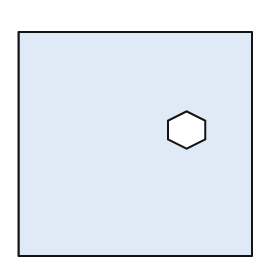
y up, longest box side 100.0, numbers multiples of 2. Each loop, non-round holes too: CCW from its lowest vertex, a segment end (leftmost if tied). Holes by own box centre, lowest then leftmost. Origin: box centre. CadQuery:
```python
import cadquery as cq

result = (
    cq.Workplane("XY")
    .moveTo(-50.0, -48.0)
    .lineTo(50.0, -48.0)
    .lineTo(50.0, 48.0)
    .lineTo(-50.0, 48.0)
    .close()
    .moveTo(22.0, -2.0)
    .lineTo(30.0, 2.0)
    .lineTo(30.0, 10.0)
    .lineTo(22.0, 14.0)
    .lineTo(14.0, 10.0)
    .lineTo(14.0, 2.0)
    .close()
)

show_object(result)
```